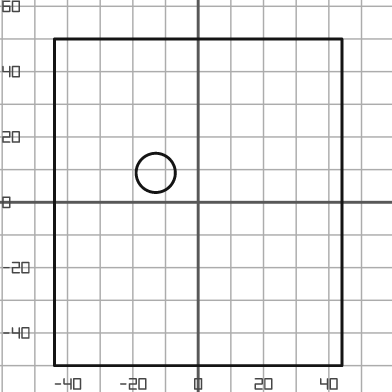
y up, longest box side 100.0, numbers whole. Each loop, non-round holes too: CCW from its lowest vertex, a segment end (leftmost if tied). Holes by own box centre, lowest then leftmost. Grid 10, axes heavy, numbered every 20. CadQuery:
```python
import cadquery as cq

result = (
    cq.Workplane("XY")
    .moveTo(-44.0, -50.0)
    .lineTo(44.0, -50.0)
    .lineTo(44.0, 50.0)
    .lineTo(-44.0, 50.0)
    .close()
    .moveTo(-13.0, 9.0)
    .circle(6.0)
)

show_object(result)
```